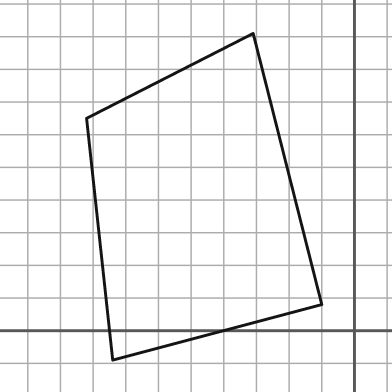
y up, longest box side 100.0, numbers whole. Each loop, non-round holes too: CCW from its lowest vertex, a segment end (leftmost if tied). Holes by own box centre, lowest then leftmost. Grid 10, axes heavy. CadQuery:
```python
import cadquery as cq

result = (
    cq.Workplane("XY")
    .moveTo(-74.0, -9.0)
    .lineTo(-10.0, 8.0)
    .lineTo(-31.0, 91.0)
    .lineTo(-82.0, 65.0)
    .close()
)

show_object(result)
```